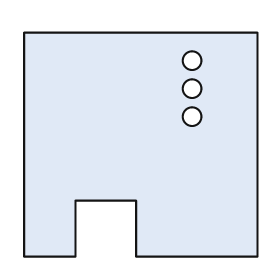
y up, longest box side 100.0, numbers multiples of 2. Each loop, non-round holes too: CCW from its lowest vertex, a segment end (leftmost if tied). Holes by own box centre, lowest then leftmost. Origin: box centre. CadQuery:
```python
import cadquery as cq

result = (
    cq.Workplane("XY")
    .moveTo(-50.0, -48.0)
    .lineTo(-28.0, -48.0)
    .lineTo(-28.0, -24.0)
    .lineTo(-2.0, -24.0)
    .lineTo(-2.0, -48.0)
    .lineTo(50.0, -48.0)
    .lineTo(50.0, 48.0)
    .lineTo(-50.0, 48.0)
    .close()
    .moveTo(22.0, 12.0)
    .circle(4.0)
    .moveTo(22.0, 24.0)
    .circle(4.0)
    .moveTo(22.0, 36.0)
    .circle(4.0)
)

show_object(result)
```